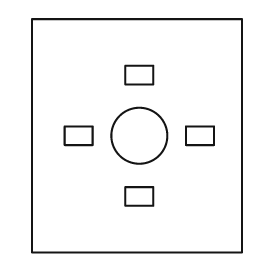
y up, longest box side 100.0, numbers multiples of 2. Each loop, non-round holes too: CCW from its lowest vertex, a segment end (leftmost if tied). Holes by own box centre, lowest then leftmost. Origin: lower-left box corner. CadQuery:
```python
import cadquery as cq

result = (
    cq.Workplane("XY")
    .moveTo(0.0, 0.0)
    .lineTo(90.0, 0.0)
    .lineTo(90.0, 100.0)
    .lineTo(0.0, 100.0)
    .close()
    .moveTo(40.0, 20.0)
    .lineTo(52.0, 20.0)
    .lineTo(52.0, 28.0)
    .lineTo(40.0, 28.0)
    .close()
    .moveTo(14.0, 46.0)
    .lineTo(26.0, 46.0)
    .lineTo(26.0, 54.0)
    .lineTo(14.0, 54.0)
    .close()
    .moveTo(46.0, 50.0)
    .circle(12.0)
    .moveTo(66.0, 46.0)
    .lineTo(78.0, 46.0)
    .lineTo(78.0, 54.0)
    .lineTo(66.0, 54.0)
    .close()
    .moveTo(40.0, 72.0)
    .lineTo(52.0, 72.0)
    .lineTo(52.0, 80.0)
    .lineTo(40.0, 80.0)
    .close()
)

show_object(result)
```